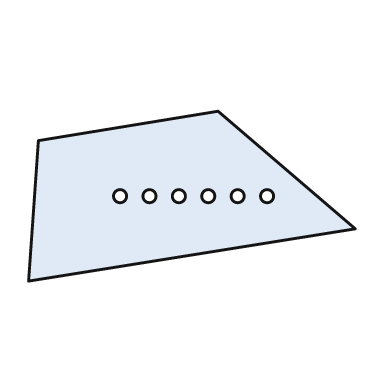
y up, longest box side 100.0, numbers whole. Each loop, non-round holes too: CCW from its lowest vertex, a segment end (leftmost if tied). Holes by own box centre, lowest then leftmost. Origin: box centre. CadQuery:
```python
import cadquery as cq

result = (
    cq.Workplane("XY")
    .moveTo(-50.0, -26.0)
    .lineTo(50.0, -10.0)
    .lineTo(8.0, 26.0)
    .lineTo(-47.0, 17.0)
    .close()
    .moveTo(-22.0, 0.0)
    .circle(2.0)
    .moveTo(-13.0, 0.0)
    .circle(2.0)
    .moveTo(-4.0, 0.0)
    .circle(2.0)
    .moveTo(5.0, 0.0)
    .circle(2.0)
    .moveTo(14.0, 0.0)
    .circle(2.0)
    .moveTo(23.0, 0.0)
    .circle(2.0)
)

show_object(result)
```